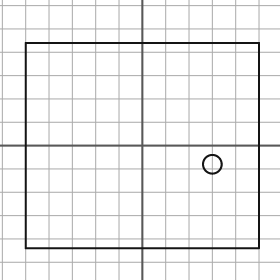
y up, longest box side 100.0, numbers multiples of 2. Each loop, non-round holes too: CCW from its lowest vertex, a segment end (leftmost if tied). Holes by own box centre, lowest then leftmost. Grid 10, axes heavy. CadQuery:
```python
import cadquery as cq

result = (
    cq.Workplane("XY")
    .moveTo(-50.0, -44.0)
    .lineTo(50.0, -44.0)
    .lineTo(50.0, 44.0)
    .lineTo(-50.0, 44.0)
    .close()
    .moveTo(30.0, -8.0)
    .circle(4.0)
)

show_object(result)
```